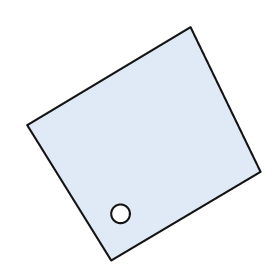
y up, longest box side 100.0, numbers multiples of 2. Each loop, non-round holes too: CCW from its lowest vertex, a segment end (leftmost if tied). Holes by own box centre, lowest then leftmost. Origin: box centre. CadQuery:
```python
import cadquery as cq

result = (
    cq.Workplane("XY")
    .moveTo(-14.0, -50.0)
    .lineTo(50.0, -12.0)
    .lineTo(20.0, 50.0)
    .lineTo(-50.0, 8.0)
    .close()
    .moveTo(-10.0, -30.0)
    .circle(4.0)
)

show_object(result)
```